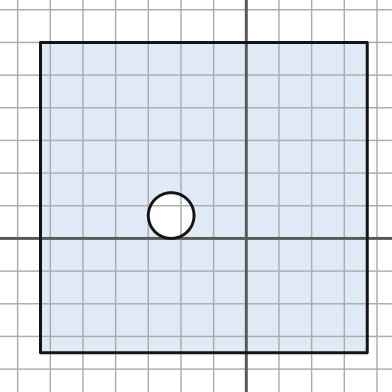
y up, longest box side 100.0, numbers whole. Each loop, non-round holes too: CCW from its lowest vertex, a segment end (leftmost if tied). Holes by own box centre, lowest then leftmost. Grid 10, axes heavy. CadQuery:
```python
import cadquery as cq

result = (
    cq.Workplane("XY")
    .moveTo(-63.0, -35.0)
    .lineTo(37.0, -35.0)
    .lineTo(37.0, 60.0)
    .lineTo(-63.0, 60.0)
    .close()
    .moveTo(-23.0, 7.0)
    .circle(7.0)
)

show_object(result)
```